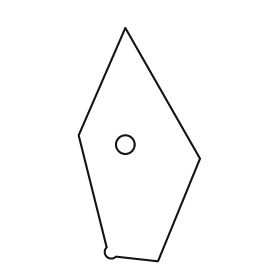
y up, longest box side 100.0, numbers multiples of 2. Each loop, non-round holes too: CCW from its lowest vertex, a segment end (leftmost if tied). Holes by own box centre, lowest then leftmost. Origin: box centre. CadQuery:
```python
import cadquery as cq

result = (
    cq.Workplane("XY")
    .moveTo(8.0, -50.0)
    .lineTo(26.0, -6.0)
    .lineTo(-6.0, 50.0)
    .lineTo(-26.0, 4.0)
    .lineTo(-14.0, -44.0)
    .threePointArc((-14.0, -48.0), (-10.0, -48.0))
    .close()
    .moveTo(-6.0, 0.0)
    .circle(4.0)
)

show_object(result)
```